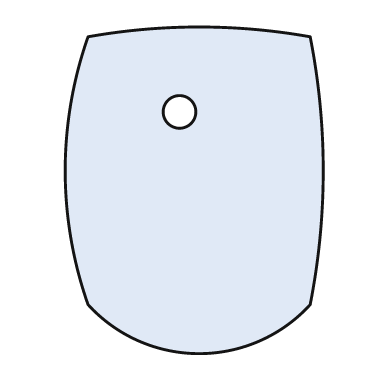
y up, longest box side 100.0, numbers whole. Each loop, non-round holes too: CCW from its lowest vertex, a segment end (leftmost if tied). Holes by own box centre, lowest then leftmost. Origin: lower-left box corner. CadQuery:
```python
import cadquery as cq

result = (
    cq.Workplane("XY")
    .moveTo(7.0, 15.0)
    .threePointArc((41.0, 0.0), (75.0, 15.0))
    .threePointArc((79.0, 56.0), (75.0, 97.0))
    .threePointArc((41.0, 100.0), (7.0, 97.0))
    .threePointArc((0.0, 56.0), (7.0, 15.0))
    .close()
    .moveTo(35.0, 74.0)
    .circle(5.0)
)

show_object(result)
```